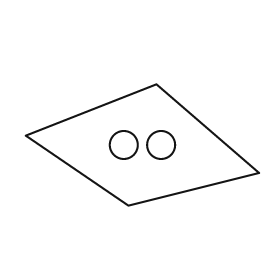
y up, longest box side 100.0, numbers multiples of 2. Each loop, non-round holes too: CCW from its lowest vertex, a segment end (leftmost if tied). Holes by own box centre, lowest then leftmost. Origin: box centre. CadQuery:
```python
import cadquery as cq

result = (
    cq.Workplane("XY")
    .moveTo(-6.0, -26.0)
    .lineTo(50.0, -12.0)
    .lineTo(6.0, 26.0)
    .lineTo(-50.0, 4.0)
    .close()
    .moveTo(-8.0, 0.0)
    .circle(6.0)
    .moveTo(8.0, 0.0)
    .circle(6.0)
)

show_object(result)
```